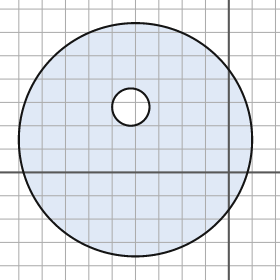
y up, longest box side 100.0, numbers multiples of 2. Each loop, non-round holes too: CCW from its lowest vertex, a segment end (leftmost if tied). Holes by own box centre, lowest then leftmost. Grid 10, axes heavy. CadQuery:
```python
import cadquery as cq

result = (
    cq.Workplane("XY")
    .moveTo(-40.0, 14.0)
    .circle(50.0)
    .moveTo(-42.0, 28.0)
    .circle(8.0)
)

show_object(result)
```